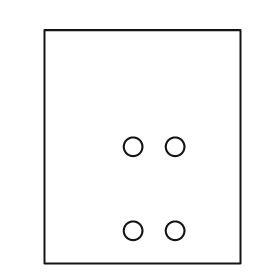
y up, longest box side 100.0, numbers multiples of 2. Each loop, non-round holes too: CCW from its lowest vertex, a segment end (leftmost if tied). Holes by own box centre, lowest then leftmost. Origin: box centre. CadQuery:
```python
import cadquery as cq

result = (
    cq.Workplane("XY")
    .moveTo(-42.0, -50.0)
    .lineTo(42.0, -50.0)
    .lineTo(42.0, 50.0)
    .lineTo(-42.0, 50.0)
    .close()
    .moveTo(-4.0, -36.0)
    .circle(4.0)
    .moveTo(14.0, -36.0)
    .circle(4.0)
    .moveTo(-4.0, 0.0)
    .circle(4.0)
    .moveTo(14.0, 0.0)
    .circle(4.0)
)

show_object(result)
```